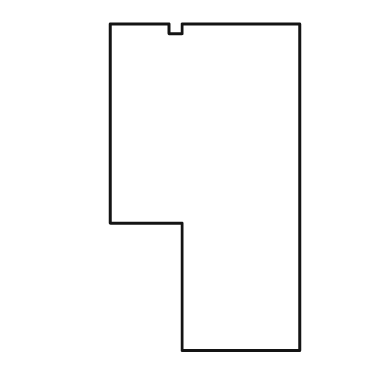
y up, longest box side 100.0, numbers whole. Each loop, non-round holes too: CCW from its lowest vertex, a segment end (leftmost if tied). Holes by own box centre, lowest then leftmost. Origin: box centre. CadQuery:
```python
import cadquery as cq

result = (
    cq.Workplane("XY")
    .moveTo(-7.0, -50.0)
    .lineTo(29.0, -50.0)
    .lineTo(29.0, 50.0)
    .lineTo(-7.0, 50.0)
    .lineTo(-7.0, 47.0)
    .lineTo(-11.0, 47.0)
    .lineTo(-11.0, 50.0)
    .lineTo(-29.0, 50.0)
    .lineTo(-29.0, -11.0)
    .lineTo(-7.0, -11.0)
    .close()
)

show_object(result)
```